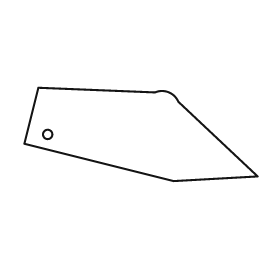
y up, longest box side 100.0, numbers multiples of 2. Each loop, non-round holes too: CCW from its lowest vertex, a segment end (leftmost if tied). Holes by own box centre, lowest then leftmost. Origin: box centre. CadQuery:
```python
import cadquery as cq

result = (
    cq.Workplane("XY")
    .moveTo(14.0, -20.0)
    .lineTo(50.0, -18.0)
    .lineTo(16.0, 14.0)
    .threePointArc((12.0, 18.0), (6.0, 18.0))
    .lineTo(-44.0, 20.0)
    .lineTo(-50.0, -4.0)
    .close()
    .moveTo(-40.0, 0.0)
    .circle(2.0)
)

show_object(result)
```